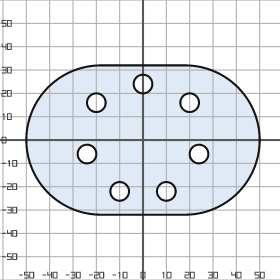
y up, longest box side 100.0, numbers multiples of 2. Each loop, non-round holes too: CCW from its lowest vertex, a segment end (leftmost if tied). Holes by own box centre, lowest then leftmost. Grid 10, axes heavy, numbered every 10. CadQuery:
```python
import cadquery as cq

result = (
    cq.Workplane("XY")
    .moveTo(-18.0, -32.0)
    .lineTo(18.0, -32.0)
    .threePointArc((50.0, 0.0), (18.0, 32.0))
    .lineTo(-18.0, 32.0)
    .threePointArc((-50.0, 0.0), (-18.0, -32.0))
    .close()
    .moveTo(-10.0, -22.0)
    .circle(4.0)
    .moveTo(10.0, -22.0)
    .circle(4.0)
    .moveTo(-24.0, -6.0)
    .circle(4.0)
    .moveTo(24.0, -6.0)
    .circle(4.0)
    .moveTo(-20.0, 16.0)
    .circle(4.0)
    .moveTo(20.0, 16.0)
    .circle(4.0)
    .moveTo(0.0, 24.0)
    .circle(4.0)
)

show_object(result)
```